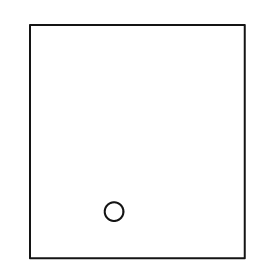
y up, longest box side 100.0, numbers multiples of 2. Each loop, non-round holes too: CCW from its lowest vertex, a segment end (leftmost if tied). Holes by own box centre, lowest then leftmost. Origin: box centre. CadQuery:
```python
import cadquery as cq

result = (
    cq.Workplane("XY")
    .moveTo(-46.0, -50.0)
    .lineTo(46.0, -50.0)
    .lineTo(46.0, 50.0)
    .lineTo(-46.0, 50.0)
    .close()
    .moveTo(-10.0, -30.0)
    .circle(4.0)
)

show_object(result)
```